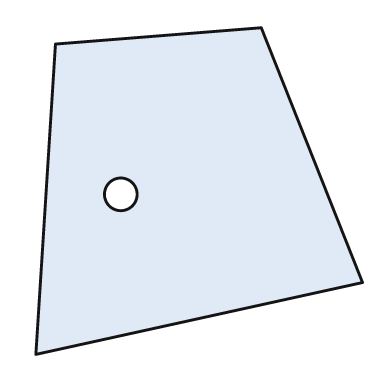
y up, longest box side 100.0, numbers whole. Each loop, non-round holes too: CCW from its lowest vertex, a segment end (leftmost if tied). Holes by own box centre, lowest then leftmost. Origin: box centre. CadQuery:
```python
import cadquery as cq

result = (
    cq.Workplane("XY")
    .moveTo(-50.0, -50.0)
    .lineTo(50.0, -28.0)
    .lineTo(19.0, 50.0)
    .lineTo(-44.0, 45.0)
    .close()
    .moveTo(-24.0, -1.0)
    .circle(5.0)
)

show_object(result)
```